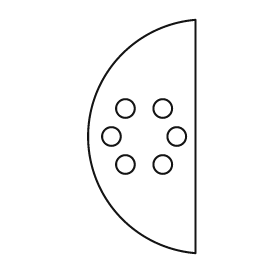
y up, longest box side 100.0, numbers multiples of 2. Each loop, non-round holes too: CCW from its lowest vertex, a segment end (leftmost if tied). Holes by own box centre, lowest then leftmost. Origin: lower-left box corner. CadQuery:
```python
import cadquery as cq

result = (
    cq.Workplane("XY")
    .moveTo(46.0, 0.0)
    .lineTo(46.0, 100.0)
    .threePointArc((0.0, 50.0), (46.0, 0.0))
    .close()
    .moveTo(16.0, 38.0)
    .circle(4.0)
    .moveTo(32.0, 38.0)
    .circle(4.0)
    .moveTo(10.0, 50.0)
    .circle(4.0)
    .moveTo(38.0, 50.0)
    .circle(4.0)
    .moveTo(16.0, 62.0)
    .circle(4.0)
    .moveTo(32.0, 62.0)
    .circle(4.0)
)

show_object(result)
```